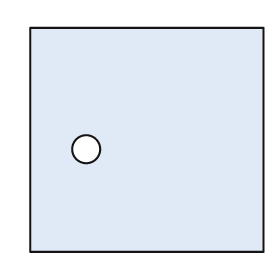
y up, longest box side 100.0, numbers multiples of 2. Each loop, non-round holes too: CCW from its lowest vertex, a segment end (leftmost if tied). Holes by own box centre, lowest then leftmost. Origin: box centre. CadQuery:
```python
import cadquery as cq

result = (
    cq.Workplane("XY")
    .moveTo(-50.0, -48.0)
    .lineTo(50.0, -48.0)
    .lineTo(50.0, 48.0)
    .lineTo(-50.0, 48.0)
    .close()
    .moveTo(-26.0, -4.0)
    .circle(6.0)
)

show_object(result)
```